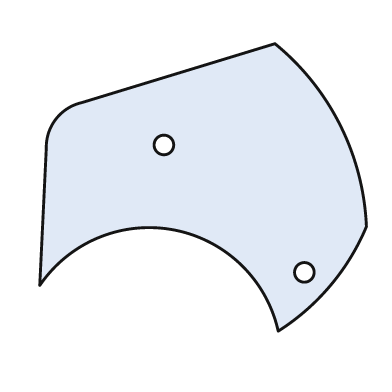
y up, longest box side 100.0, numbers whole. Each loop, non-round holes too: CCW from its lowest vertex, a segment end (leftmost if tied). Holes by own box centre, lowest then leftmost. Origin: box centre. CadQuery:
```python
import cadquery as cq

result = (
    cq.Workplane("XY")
    .moveTo(23.0, -44.0)
    .threePointArc((39.0, -30.0), (50.0, -12.0))
    .threePointArc((42.0, 19.0), (22.0, 44.0))
    .lineTo(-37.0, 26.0)
    .threePointArc((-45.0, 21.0), (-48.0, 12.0))
    .lineTo(-50.0, -30.0)
    .threePointArc((-9.0, -13.0), (23.0, -44.0))
    .close()
    .moveTo(31.0, -26.0)
    .circle(3.0)
    .moveTo(-12.0, 13.0)
    .circle(3.0)
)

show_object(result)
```